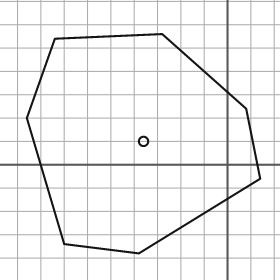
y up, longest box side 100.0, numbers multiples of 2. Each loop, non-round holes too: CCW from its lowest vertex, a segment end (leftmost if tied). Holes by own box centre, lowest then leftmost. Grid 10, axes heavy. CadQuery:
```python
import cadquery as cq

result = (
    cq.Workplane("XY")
    .moveTo(-38.0, -38.0)
    .lineTo(14.0, -6.0)
    .lineTo(8.0, 24.0)
    .lineTo(-28.0, 56.0)
    .lineTo(-74.0, 54.0)
    .lineTo(-86.0, 20.0)
    .lineTo(-70.0, -34.0)
    .close()
    .moveTo(-36.0, 10.0)
    .circle(2.0)
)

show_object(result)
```